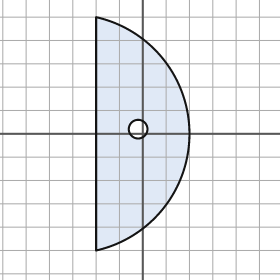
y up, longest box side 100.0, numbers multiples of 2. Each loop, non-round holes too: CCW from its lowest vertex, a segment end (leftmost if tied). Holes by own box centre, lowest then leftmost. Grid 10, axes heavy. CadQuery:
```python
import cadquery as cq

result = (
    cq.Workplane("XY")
    .moveTo(-20.0, -50.0)
    .threePointArc((20.0, 0.0), (-20.0, 50.0))
    .close()
    .moveTo(-2.0, 2.0)
    .circle(4.0)
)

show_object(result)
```